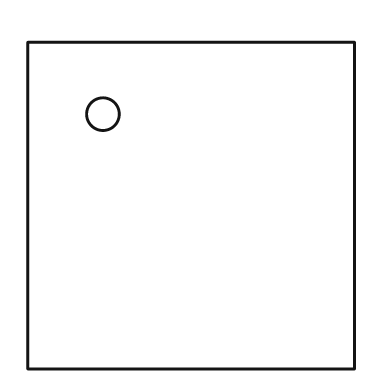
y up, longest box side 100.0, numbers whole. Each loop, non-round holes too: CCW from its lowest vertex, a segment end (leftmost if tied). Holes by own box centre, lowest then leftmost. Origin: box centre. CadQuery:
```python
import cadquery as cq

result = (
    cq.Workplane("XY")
    .moveTo(-50.0, -50.0)
    .lineTo(50.0, -50.0)
    .lineTo(50.0, 50.0)
    .lineTo(-50.0, 50.0)
    .close()
    .moveTo(-27.0, 28.0)
    .circle(5.0)
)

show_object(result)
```